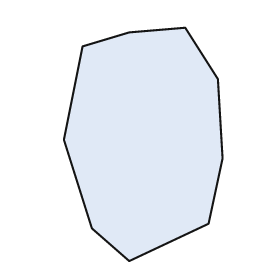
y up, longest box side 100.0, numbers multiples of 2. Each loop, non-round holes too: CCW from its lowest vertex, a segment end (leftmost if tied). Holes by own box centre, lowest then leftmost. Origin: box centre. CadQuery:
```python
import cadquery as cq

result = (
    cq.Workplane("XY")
    .moveTo(-6.0, -50.0)
    .lineTo(28.0, -34.0)
    .lineTo(34.0, -6.0)
    .lineTo(32.0, 28.0)
    .lineTo(18.0, 50.0)
    .lineTo(-6.0, 48.0)
    .lineTo(-26.0, 42.0)
    .lineTo(-34.0, 2.0)
    .lineTo(-22.0, -36.0)
    .close()
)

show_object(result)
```